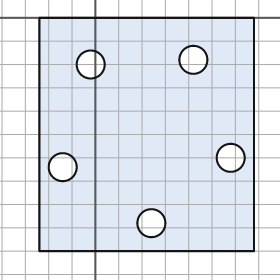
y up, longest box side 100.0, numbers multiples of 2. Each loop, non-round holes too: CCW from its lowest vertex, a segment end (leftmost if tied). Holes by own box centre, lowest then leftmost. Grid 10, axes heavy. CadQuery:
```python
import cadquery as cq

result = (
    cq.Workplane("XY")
    .moveTo(-24.0, -100.0)
    .lineTo(68.0, -100.0)
    .lineTo(68.0, 0.0)
    .lineTo(-24.0, 0.0)
    .close()
    .moveTo(24.0, -88.0)
    .circle(6.0)
    .moveTo(-14.0, -64.0)
    .circle(6.0)
    .moveTo(58.0, -60.0)
    .circle(6.0)
    .moveTo(-2.0, -20.0)
    .circle(6.0)
    .moveTo(42.0, -18.0)
    .circle(6.0)
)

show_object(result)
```